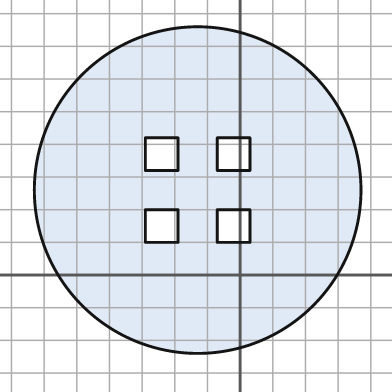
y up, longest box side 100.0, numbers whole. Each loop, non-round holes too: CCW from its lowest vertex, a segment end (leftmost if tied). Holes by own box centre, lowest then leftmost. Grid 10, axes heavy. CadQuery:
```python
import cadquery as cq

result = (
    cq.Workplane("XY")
    .moveTo(-13.0, 26.0)
    .circle(50.0)
    .moveTo(-29.0, 10.0)
    .lineTo(-19.0, 10.0)
    .lineTo(-19.0, 20.0)
    .lineTo(-29.0, 20.0)
    .close()
    .moveTo(-7.0, 10.0)
    .lineTo(3.0, 10.0)
    .lineTo(3.0, 20.0)
    .lineTo(-7.0, 20.0)
    .close()
    .moveTo(-29.0, 32.0)
    .lineTo(-19.0, 32.0)
    .lineTo(-19.0, 42.0)
    .lineTo(-29.0, 42.0)
    .close()
    .moveTo(-7.0, 32.0)
    .lineTo(3.0, 32.0)
    .lineTo(3.0, 42.0)
    .lineTo(-7.0, 42.0)
    .close()
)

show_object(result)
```